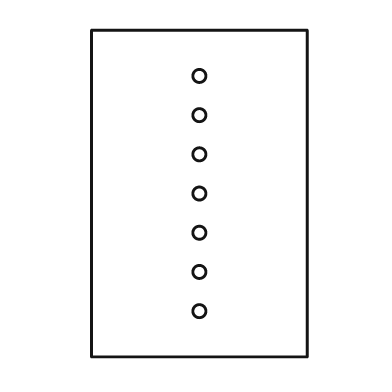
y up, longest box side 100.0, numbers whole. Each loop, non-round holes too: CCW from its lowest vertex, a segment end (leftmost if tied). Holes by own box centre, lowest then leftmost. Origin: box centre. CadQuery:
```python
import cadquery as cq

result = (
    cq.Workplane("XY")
    .moveTo(-33.0, -50.0)
    .lineTo(33.0, -50.0)
    .lineTo(33.0, 50.0)
    .lineTo(-33.0, 50.0)
    .close()
    .moveTo(0.0, -36.0)
    .circle(2.0)
    .moveTo(0.0, -24.0)
    .circle(2.0)
    .moveTo(0.0, -12.0)
    .circle(2.0)
    .moveTo(0.0, 0.0)
    .circle(2.0)
    .moveTo(0.0, 12.0)
    .circle(2.0)
    .moveTo(0.0, 24.0)
    .circle(2.0)
    .moveTo(0.0, 36.0)
    .circle(2.0)
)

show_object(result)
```